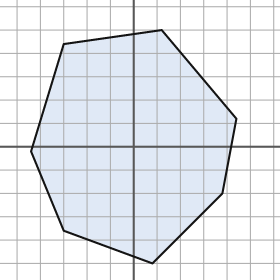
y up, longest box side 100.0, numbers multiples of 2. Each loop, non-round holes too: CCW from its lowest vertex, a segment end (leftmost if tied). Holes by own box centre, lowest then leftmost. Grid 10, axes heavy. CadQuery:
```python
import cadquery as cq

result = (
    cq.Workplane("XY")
    .moveTo(8.0, -50.0)
    .lineTo(38.0, -20.0)
    .lineTo(44.0, 12.0)
    .lineTo(12.0, 50.0)
    .lineTo(-30.0, 44.0)
    .lineTo(-44.0, -2.0)
    .lineTo(-30.0, -36.0)
    .close()
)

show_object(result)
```